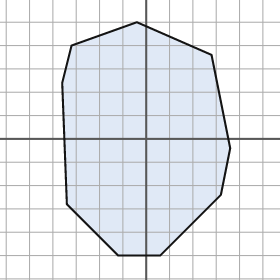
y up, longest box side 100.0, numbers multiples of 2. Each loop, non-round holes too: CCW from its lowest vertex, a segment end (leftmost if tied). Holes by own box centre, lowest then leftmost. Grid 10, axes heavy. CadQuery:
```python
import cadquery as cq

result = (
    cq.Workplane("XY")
    .moveTo(-12.0, -50.0)
    .lineTo(6.0, -50.0)
    .lineTo(32.0, -24.0)
    .lineTo(36.0, -4.0)
    .lineTo(28.0, 36.0)
    .lineTo(-4.0, 50.0)
    .lineTo(-32.0, 40.0)
    .lineTo(-36.0, 24.0)
    .lineTo(-34.0, -28.0)
    .close()
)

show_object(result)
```